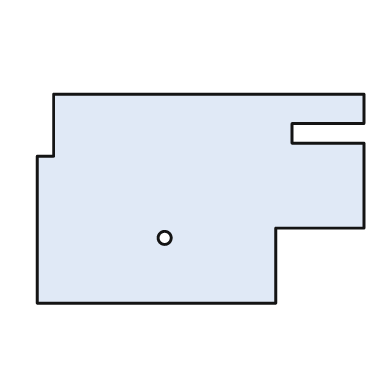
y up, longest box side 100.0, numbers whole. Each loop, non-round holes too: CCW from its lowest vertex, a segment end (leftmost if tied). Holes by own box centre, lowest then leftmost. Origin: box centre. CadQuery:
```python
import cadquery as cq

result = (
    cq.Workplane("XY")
    .moveTo(-50.0, -32.0)
    .lineTo(23.0, -32.0)
    .lineTo(23.0, -9.0)
    .lineTo(50.0, -9.0)
    .lineTo(50.0, 17.0)
    .lineTo(28.0, 17.0)
    .lineTo(28.0, 23.0)
    .lineTo(50.0, 23.0)
    .lineTo(50.0, 32.0)
    .lineTo(-45.0, 32.0)
    .lineTo(-45.0, 13.0)
    .lineTo(-50.0, 13.0)
    .close()
    .moveTo(-11.0, -12.0)
    .circle(2.0)
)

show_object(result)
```